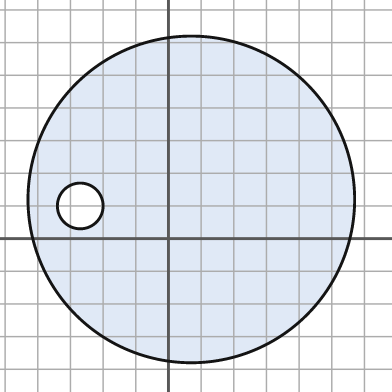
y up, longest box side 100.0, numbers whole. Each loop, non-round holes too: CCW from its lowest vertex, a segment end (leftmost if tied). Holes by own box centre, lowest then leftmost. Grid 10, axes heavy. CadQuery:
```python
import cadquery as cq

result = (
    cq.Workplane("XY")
    .moveTo(7.0, 12.0)
    .circle(50.0)
    .moveTo(-27.0, 10.0)
    .circle(7.0)
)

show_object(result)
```